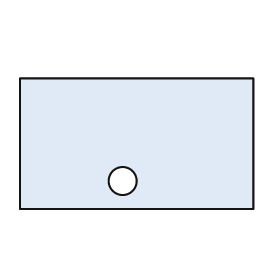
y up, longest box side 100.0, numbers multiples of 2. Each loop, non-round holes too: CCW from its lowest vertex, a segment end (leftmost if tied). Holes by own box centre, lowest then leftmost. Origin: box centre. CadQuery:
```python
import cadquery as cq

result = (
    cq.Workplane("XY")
    .moveTo(-50.0, -28.0)
    .lineTo(50.0, -28.0)
    .lineTo(50.0, 28.0)
    .lineTo(-50.0, 28.0)
    .close()
    .moveTo(-6.0, -16.0)
    .circle(6.0)
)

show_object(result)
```